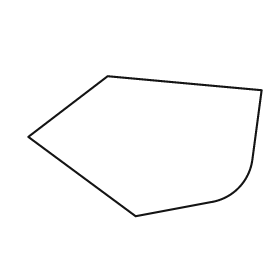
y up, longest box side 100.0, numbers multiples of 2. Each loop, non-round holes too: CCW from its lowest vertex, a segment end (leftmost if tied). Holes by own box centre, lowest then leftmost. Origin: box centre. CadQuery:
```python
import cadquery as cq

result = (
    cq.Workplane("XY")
    .moveTo(-4.0, -30.0)
    .lineTo(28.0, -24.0)
    .threePointArc((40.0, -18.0), (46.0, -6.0))
    .lineTo(50.0, 24.0)
    .lineTo(-16.0, 30.0)
    .lineTo(-50.0, 4.0)
    .close()
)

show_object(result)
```